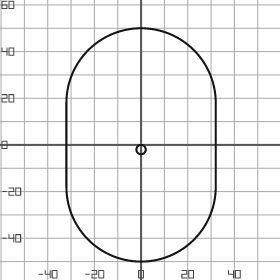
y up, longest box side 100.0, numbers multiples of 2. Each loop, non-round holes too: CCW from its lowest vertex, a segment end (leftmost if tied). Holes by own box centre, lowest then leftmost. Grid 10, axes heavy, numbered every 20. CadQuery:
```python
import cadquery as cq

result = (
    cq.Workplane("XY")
    .moveTo(-32.0, -18.0)
    .threePointArc((0.0, -50.0), (32.0, -18.0))
    .lineTo(32.0, 18.0)
    .threePointArc((0.0, 50.0), (-32.0, 18.0))
    .close()
    .moveTo(0.0, -2.0)
    .circle(2.0)
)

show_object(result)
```